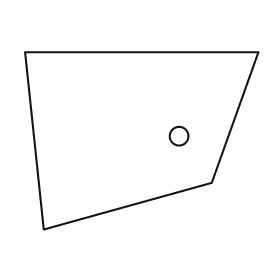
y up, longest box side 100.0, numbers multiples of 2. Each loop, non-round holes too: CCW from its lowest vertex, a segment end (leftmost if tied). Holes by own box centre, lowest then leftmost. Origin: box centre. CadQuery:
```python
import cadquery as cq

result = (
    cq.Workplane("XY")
    .moveTo(-42.0, -38.0)
    .lineTo(30.0, -18.0)
    .lineTo(50.0, 38.0)
    .lineTo(-50.0, 38.0)
    .close()
    .moveTo(16.0, 2.0)
    .circle(4.0)
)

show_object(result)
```